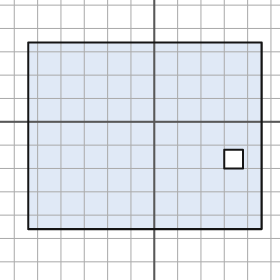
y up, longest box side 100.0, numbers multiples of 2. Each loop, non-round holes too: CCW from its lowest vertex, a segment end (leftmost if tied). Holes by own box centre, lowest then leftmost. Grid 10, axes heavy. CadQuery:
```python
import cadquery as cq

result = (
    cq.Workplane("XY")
    .moveTo(-54.0, -46.0)
    .lineTo(46.0, -46.0)
    .lineTo(46.0, 34.0)
    .lineTo(-54.0, 34.0)
    .close()
    .moveTo(30.0, -20.0)
    .lineTo(38.0, -20.0)
    .lineTo(38.0, -12.0)
    .lineTo(30.0, -12.0)
    .close()
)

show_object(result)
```